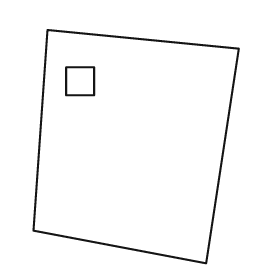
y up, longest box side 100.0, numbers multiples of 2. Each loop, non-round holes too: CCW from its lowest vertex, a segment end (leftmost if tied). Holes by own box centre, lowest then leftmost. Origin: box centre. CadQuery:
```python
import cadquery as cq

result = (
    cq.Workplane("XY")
    .moveTo(30.0, -50.0)
    .lineTo(44.0, 42.0)
    .lineTo(-38.0, 50.0)
    .lineTo(-44.0, -36.0)
    .close()
    .moveTo(-30.0, 22.0)
    .lineTo(-18.0, 22.0)
    .lineTo(-18.0, 34.0)
    .lineTo(-30.0, 34.0)
    .close()
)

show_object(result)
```